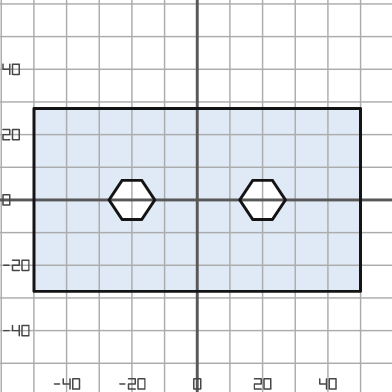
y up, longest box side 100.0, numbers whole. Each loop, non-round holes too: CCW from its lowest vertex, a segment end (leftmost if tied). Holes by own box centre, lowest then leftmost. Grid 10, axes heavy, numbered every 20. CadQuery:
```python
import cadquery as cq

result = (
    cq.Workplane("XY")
    .moveTo(-50.0, -28.0)
    .lineTo(50.0, -28.0)
    .lineTo(50.0, 28.0)
    .lineTo(-50.0, 28.0)
    .close()
    .moveTo(-23.0, -6.0)
    .lineTo(-17.0, -6.0)
    .lineTo(-13.0, 0.0)
    .lineTo(-17.0, 6.0)
    .lineTo(-23.0, 6.0)
    .lineTo(-27.0, 0.0)
    .close()
    .moveTo(17.0, -6.0)
    .lineTo(23.0, -6.0)
    .lineTo(27.0, 0.0)
    .lineTo(23.0, 6.0)
    .lineTo(17.0, 6.0)
    .lineTo(13.0, 0.0)
    .close()
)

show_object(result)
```